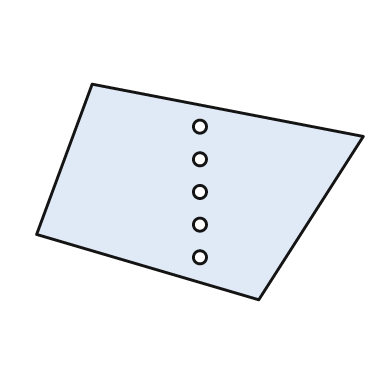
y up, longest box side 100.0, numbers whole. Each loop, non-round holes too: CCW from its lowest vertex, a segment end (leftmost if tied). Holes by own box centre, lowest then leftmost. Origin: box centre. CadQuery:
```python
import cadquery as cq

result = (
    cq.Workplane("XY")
    .moveTo(18.0, -33.0)
    .lineTo(50.0, 17.0)
    .lineTo(-33.0, 33.0)
    .lineTo(-50.0, -13.0)
    .close()
    .moveTo(0.0, -20.0)
    .circle(2.0)
    .moveTo(0.0, -10.0)
    .circle(2.0)
    .moveTo(0.0, 0.0)
    .circle(2.0)
    .moveTo(0.0, 10.0)
    .circle(2.0)
    .moveTo(0.0, 20.0)
    .circle(2.0)
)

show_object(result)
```